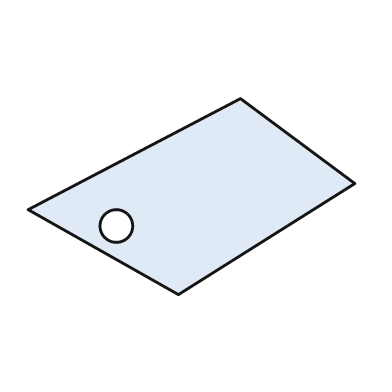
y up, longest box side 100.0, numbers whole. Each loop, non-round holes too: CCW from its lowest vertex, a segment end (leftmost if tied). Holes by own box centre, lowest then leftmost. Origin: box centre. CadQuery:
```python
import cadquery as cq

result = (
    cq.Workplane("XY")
    .moveTo(-4.0, -30.0)
    .lineTo(50.0, 4.0)
    .lineTo(15.0, 30.0)
    .lineTo(-50.0, -4.0)
    .close()
    .moveTo(-23.0, -9.0)
    .circle(5.0)
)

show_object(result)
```